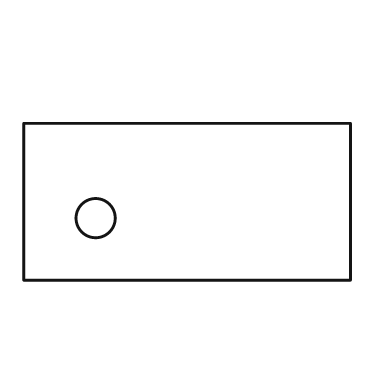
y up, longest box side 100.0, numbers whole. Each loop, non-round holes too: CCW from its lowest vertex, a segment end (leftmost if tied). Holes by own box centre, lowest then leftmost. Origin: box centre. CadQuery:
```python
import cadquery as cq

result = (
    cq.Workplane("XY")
    .moveTo(-50.0, -24.0)
    .lineTo(50.0, -24.0)
    .lineTo(50.0, 24.0)
    .lineTo(-50.0, 24.0)
    .close()
    .moveTo(-28.0, -5.0)
    .circle(6.0)
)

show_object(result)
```